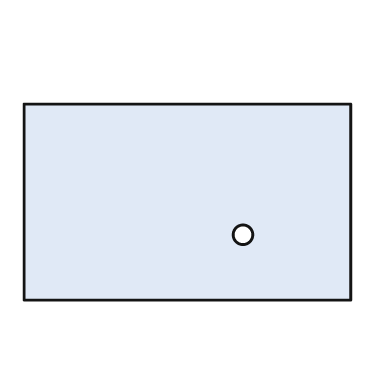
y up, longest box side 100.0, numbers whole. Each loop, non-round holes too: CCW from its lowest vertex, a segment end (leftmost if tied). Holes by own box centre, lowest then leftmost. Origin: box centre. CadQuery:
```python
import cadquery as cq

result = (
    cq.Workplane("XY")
    .moveTo(-50.0, -30.0)
    .lineTo(50.0, -30.0)
    .lineTo(50.0, 30.0)
    .lineTo(-50.0, 30.0)
    .close()
    .moveTo(17.0, -10.0)
    .circle(3.0)
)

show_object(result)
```